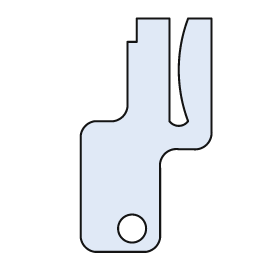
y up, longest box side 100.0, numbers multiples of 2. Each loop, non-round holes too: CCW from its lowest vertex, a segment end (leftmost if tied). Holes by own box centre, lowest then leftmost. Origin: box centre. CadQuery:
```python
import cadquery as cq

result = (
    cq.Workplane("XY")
    .moveTo(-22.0, -50.0)
    .lineTo(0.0, -50.0)
    .threePointArc((4.0, -48.0), (6.0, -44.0))
    .lineTo(6.0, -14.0)
    .threePointArc((8.0, -8.0), (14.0, -6.0))
    .lineTo(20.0, -6.0)
    .threePointArc((26.0, -4.0), (28.0, 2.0))
    .lineTo(28.0, 50.0)
    .lineTo(18.0, 50.0)
    .threePointArc((14.0, 28.0), (18.0, 6.0))
    .threePointArc((14.0, 4.0), (10.0, 6.0))
    .lineTo(10.0, 50.0)
    .lineTo(-4.0, 50.0)
    .lineTo(-4.0, 40.0)
    .lineTo(-8.0, 40.0)
    .lineTo(-8.0, 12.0)
    .threePointArc((-10.0, 8.0), (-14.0, 6.0))
    .lineTo(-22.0, 6.0)
    .threePointArc((-26.0, 4.0), (-28.0, 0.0))
    .lineTo(-28.0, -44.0)
    .threePointArc((-26.0, -48.0), (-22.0, -50.0))
    .close()
    .moveTo(-6.0, -40.0)
    .circle(6.0)
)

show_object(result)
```